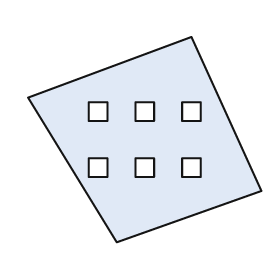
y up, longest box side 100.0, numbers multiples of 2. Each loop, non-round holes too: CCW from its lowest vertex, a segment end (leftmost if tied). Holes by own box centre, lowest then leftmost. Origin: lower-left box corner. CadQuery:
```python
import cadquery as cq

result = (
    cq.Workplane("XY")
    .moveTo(38.0, 0.0)
    .lineTo(100.0, 22.0)
    .lineTo(70.0, 88.0)
    .lineTo(0.0, 62.0)
    .close()
    .moveTo(26.0, 28.0)
    .lineTo(34.0, 28.0)
    .lineTo(34.0, 36.0)
    .lineTo(26.0, 36.0)
    .close()
    .moveTo(46.0, 28.0)
    .lineTo(54.0, 28.0)
    .lineTo(54.0, 36.0)
    .lineTo(46.0, 36.0)
    .close()
    .moveTo(66.0, 28.0)
    .lineTo(74.0, 28.0)
    .lineTo(74.0, 36.0)
    .lineTo(66.0, 36.0)
    .close()
    .moveTo(26.0, 52.0)
    .lineTo(34.0, 52.0)
    .lineTo(34.0, 60.0)
    .lineTo(26.0, 60.0)
    .close()
    .moveTo(46.0, 52.0)
    .lineTo(54.0, 52.0)
    .lineTo(54.0, 60.0)
    .lineTo(46.0, 60.0)
    .close()
    .moveTo(66.0, 52.0)
    .lineTo(74.0, 52.0)
    .lineTo(74.0, 60.0)
    .lineTo(66.0, 60.0)
    .close()
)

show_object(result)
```